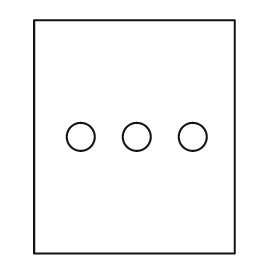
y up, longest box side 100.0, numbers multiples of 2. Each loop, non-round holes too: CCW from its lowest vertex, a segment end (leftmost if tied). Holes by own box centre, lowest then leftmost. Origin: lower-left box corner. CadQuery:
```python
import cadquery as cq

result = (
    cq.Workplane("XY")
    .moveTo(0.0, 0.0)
    .lineTo(86.0, 0.0)
    .lineTo(86.0, 100.0)
    .lineTo(0.0, 100.0)
    .close()
    .moveTo(20.0, 50.0)
    .circle(6.0)
    .moveTo(44.0, 50.0)
    .circle(6.0)
    .moveTo(68.0, 50.0)
    .circle(6.0)
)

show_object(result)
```